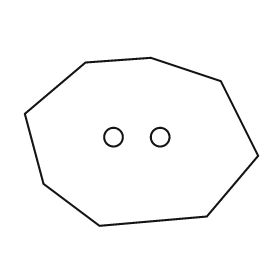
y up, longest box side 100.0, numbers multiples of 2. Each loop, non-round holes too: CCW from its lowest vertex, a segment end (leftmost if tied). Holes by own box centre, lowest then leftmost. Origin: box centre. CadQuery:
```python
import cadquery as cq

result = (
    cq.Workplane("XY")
    .moveTo(-18.0, -36.0)
    .lineTo(28.0, -32.0)
    .lineTo(50.0, -6.0)
    .lineTo(34.0, 26.0)
    .lineTo(4.0, 36.0)
    .lineTo(-24.0, 34.0)
    .lineTo(-50.0, 12.0)
    .lineTo(-42.0, -18.0)
    .close()
    .moveTo(-12.0, 2.0)
    .circle(4.0)
    .moveTo(8.0, 2.0)
    .circle(4.0)
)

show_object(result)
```